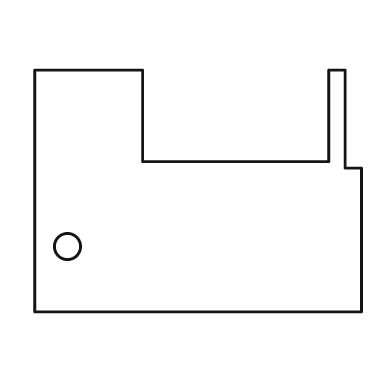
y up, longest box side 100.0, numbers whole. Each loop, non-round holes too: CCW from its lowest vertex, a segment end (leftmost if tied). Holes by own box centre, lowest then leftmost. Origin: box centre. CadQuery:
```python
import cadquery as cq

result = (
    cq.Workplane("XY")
    .moveTo(-50.0, -37.0)
    .lineTo(50.0, -37.0)
    .lineTo(50.0, 7.0)
    .lineTo(45.0, 7.0)
    .lineTo(45.0, 37.0)
    .lineTo(40.0, 37.0)
    .lineTo(40.0, 9.0)
    .lineTo(-17.0, 9.0)
    .lineTo(-17.0, 37.0)
    .lineTo(-50.0, 37.0)
    .close()
    .moveTo(-40.0, -17.0)
    .circle(4.0)
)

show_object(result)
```